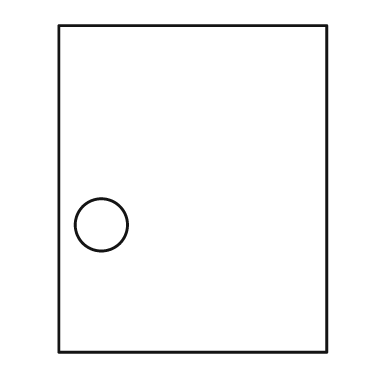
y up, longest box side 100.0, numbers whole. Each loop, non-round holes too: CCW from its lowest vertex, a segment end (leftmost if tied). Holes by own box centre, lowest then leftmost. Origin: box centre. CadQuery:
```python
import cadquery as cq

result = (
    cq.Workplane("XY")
    .moveTo(-41.0, -50.0)
    .lineTo(41.0, -50.0)
    .lineTo(41.0, 50.0)
    .lineTo(-41.0, 50.0)
    .close()
    .moveTo(-28.0, -11.0)
    .circle(8.0)
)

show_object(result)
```